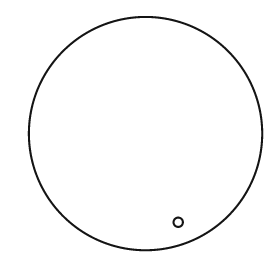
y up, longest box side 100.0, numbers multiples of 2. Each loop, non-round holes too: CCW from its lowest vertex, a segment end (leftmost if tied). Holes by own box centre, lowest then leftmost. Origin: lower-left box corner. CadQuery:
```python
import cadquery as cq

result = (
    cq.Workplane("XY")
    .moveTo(50.0, 50.0)
    .circle(50.0)
    .moveTo(64.0, 12.0)
    .circle(2.0)
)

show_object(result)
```